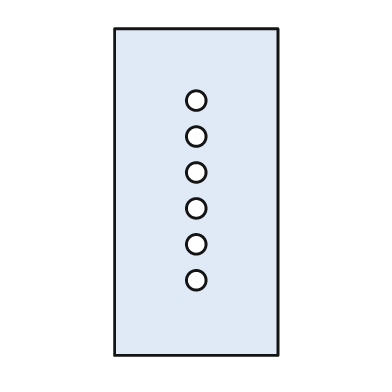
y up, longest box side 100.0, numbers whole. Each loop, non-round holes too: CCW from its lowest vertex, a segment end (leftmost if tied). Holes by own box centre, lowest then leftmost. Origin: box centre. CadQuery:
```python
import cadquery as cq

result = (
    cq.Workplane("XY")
    .moveTo(-25.0, -50.0)
    .lineTo(25.0, -50.0)
    .lineTo(25.0, 50.0)
    .lineTo(-25.0, 50.0)
    .close()
    .moveTo(0.0, -27.0)
    .circle(3.0)
    .moveTo(0.0, -16.0)
    .circle(3.0)
    .moveTo(0.0, -5.0)
    .circle(3.0)
    .moveTo(0.0, 6.0)
    .circle(3.0)
    .moveTo(0.0, 17.0)
    .circle(3.0)
    .moveTo(0.0, 28.0)
    .circle(3.0)
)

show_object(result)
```